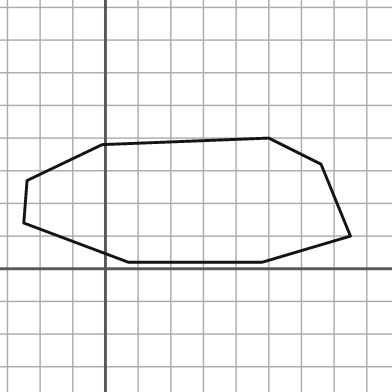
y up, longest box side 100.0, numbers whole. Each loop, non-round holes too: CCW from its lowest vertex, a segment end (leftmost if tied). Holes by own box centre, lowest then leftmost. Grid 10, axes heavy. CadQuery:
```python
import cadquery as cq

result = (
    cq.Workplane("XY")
    .moveTo(7.0, 2.0)
    .lineTo(48.0, 2.0)
    .lineTo(75.0, 10.0)
    .lineTo(66.0, 32.0)
    .lineTo(50.0, 40.0)
    .lineTo(-1.0, 38.0)
    .lineTo(-24.0, 27.0)
    .lineTo(-25.0, 14.0)
    .close()
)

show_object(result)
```